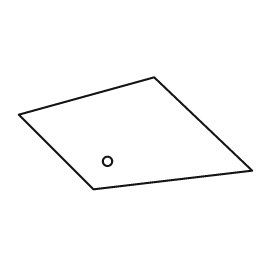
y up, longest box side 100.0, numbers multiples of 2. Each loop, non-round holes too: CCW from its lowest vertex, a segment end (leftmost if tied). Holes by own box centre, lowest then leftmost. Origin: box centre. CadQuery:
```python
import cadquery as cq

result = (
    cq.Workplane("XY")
    .moveTo(-18.0, -24.0)
    .lineTo(50.0, -16.0)
    .lineTo(8.0, 24.0)
    .lineTo(-50.0, 8.0)
    .close()
    .moveTo(-12.0, -12.0)
    .circle(2.0)
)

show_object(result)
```